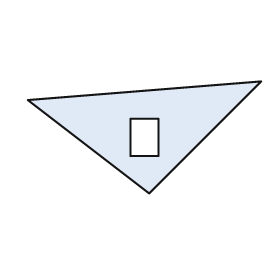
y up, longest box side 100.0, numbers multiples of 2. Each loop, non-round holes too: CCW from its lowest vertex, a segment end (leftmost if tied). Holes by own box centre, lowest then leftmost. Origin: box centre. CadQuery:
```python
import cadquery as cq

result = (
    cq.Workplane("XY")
    .moveTo(2.0, -24.0)
    .lineTo(50.0, 24.0)
    .lineTo(-50.0, 16.0)
    .close()
    .moveTo(-6.0, -8.0)
    .lineTo(6.0, -8.0)
    .lineTo(6.0, 8.0)
    .lineTo(-6.0, 8.0)
    .close()
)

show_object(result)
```